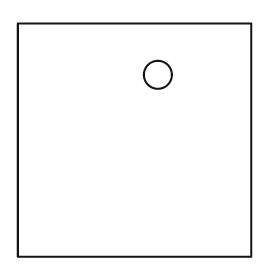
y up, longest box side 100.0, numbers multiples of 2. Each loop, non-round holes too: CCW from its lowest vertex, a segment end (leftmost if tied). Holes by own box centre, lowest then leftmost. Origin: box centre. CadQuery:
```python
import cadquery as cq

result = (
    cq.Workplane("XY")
    .moveTo(-50.0, -50.0)
    .lineTo(50.0, -50.0)
    .lineTo(50.0, 50.0)
    .lineTo(-50.0, 50.0)
    .close()
    .moveTo(10.0, 28.0)
    .circle(6.0)
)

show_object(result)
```